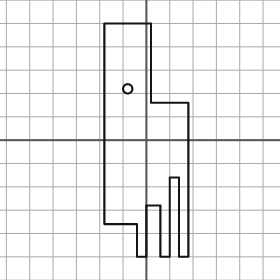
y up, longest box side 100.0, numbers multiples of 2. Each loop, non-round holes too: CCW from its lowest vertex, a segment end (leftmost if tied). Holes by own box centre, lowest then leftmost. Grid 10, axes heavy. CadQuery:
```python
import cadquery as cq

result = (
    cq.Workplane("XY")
    .moveTo(-4.0, -50.0)
    .lineTo(0.0, -50.0)
    .lineTo(0.0, -28.0)
    .lineTo(6.0, -28.0)
    .lineTo(6.0, -50.0)
    .lineTo(10.0, -50.0)
    .lineTo(10.0, -16.0)
    .lineTo(14.0, -16.0)
    .lineTo(14.0, -50.0)
    .lineTo(18.0, -50.0)
    .lineTo(18.0, 16.0)
    .lineTo(2.0, 16.0)
    .lineTo(2.0, 50.0)
    .lineTo(-18.0, 50.0)
    .lineTo(-18.0, -36.0)
    .lineTo(-4.0, -36.0)
    .close()
    .moveTo(-8.0, 22.0)
    .circle(2.0)
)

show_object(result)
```